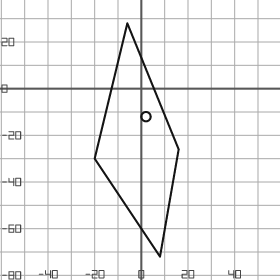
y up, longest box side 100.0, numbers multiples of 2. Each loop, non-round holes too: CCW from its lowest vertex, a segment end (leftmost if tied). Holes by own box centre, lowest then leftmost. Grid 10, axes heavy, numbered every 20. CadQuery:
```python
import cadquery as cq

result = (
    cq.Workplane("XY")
    .moveTo(8.0, -72.0)
    .lineTo(16.0, -26.0)
    .lineTo(-6.0, 28.0)
    .lineTo(-20.0, -30.0)
    .close()
    .moveTo(2.0, -12.0)
    .circle(2.0)
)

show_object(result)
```